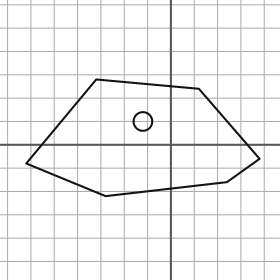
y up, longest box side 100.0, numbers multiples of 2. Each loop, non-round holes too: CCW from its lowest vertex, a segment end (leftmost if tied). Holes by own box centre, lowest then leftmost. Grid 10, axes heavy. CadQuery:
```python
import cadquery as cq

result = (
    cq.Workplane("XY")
    .moveTo(-28.0, -22.0)
    .lineTo(24.0, -16.0)
    .lineTo(38.0, -6.0)
    .lineTo(12.0, 24.0)
    .lineTo(-32.0, 28.0)
    .lineTo(-62.0, -8.0)
    .close()
    .moveTo(-12.0, 10.0)
    .circle(4.0)
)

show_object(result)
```